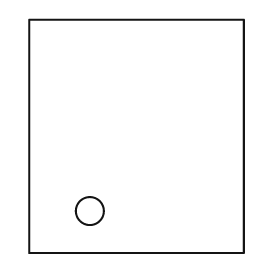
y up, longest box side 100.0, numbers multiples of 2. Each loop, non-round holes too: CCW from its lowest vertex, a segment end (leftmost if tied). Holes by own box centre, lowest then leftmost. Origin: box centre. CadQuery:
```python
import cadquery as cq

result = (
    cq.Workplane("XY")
    .moveTo(-46.0, -50.0)
    .lineTo(46.0, -50.0)
    .lineTo(46.0, 50.0)
    .lineTo(-46.0, 50.0)
    .close()
    .moveTo(-20.0, -32.0)
    .circle(6.0)
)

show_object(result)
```